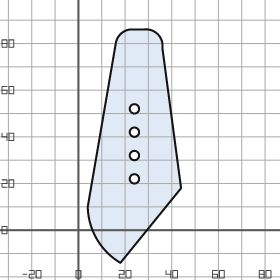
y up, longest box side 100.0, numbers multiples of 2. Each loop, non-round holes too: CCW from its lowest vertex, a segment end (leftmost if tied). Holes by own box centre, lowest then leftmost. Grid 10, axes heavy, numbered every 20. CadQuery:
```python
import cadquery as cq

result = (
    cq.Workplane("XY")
    .moveTo(18.0, -14.0)
    .lineTo(44.0, 18.0)
    .lineTo(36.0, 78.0)
    .threePointArc((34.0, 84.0), (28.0, 86.0))
    .lineTo(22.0, 86.0)
    .threePointArc((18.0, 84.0), (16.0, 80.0))
    .lineTo(4.0, 10.0)
    .threePointArc((8.0, -4.0), (18.0, -14.0))
    .close()
    .moveTo(24.0, 22.0)
    .circle(2.0)
    .moveTo(24.0, 32.0)
    .circle(2.0)
    .moveTo(24.0, 42.0)
    .circle(2.0)
    .moveTo(24.0, 52.0)
    .circle(2.0)
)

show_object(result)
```